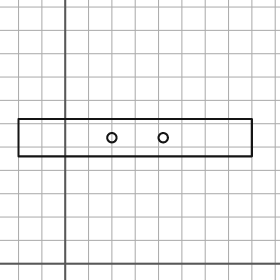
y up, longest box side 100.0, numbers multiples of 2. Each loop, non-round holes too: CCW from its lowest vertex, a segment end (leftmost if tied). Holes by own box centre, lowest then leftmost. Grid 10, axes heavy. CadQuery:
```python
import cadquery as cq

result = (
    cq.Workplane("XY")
    .moveTo(-20.0, 46.0)
    .lineTo(80.0, 46.0)
    .lineTo(80.0, 62.0)
    .lineTo(-20.0, 62.0)
    .close()
    .moveTo(20.0, 54.0)
    .circle(2.0)
    .moveTo(42.0, 54.0)
    .circle(2.0)
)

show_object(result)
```